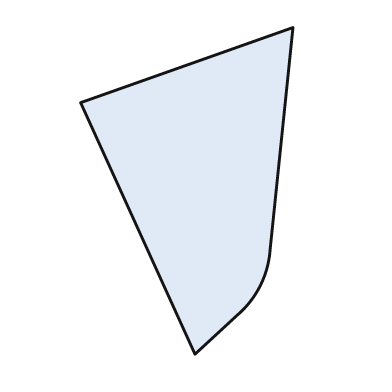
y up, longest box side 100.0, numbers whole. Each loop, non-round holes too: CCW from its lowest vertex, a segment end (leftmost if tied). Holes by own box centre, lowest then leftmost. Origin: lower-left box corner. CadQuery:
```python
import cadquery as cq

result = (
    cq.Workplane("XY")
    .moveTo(35.0, 0.0)
    .lineTo(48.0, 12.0)
    .threePointArc((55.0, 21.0), (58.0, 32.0))
    .lineTo(65.0, 100.0)
    .lineTo(0.0, 77.0)
    .close()
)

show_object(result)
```